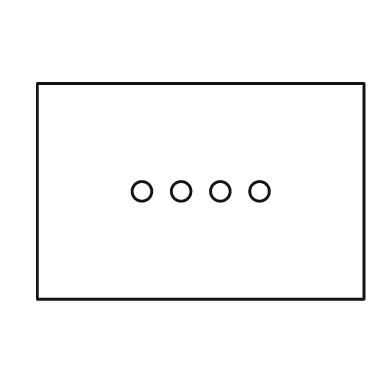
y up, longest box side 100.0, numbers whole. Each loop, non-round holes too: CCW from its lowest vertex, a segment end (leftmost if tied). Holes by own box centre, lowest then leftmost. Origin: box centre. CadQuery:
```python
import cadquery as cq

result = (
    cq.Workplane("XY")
    .moveTo(-50.0, -33.0)
    .lineTo(50.0, -33.0)
    .lineTo(50.0, 33.0)
    .lineTo(-50.0, 33.0)
    .close()
    .moveTo(-18.0, 0.0)
    .circle(3.0)
    .moveTo(-6.0, 0.0)
    .circle(3.0)
    .moveTo(6.0, 0.0)
    .circle(3.0)
    .moveTo(18.0, 0.0)
    .circle(3.0)
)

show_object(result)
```